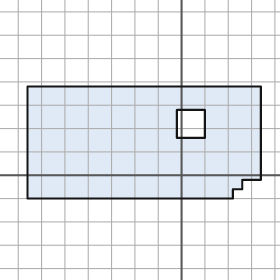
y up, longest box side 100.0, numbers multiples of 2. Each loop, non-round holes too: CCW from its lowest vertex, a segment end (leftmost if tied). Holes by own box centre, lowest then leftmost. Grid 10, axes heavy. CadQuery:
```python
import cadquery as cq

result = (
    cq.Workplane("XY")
    .moveTo(-66.0, -10.0)
    .lineTo(22.0, -10.0)
    .lineTo(22.0, -6.0)
    .lineTo(26.0, -6.0)
    .lineTo(26.0, -2.0)
    .lineTo(34.0, -2.0)
    .lineTo(34.0, 38.0)
    .lineTo(-66.0, 38.0)
    .close()
    .moveTo(-2.0, 16.0)
    .lineTo(10.0, 16.0)
    .lineTo(10.0, 28.0)
    .lineTo(-2.0, 28.0)
    .close()
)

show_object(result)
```